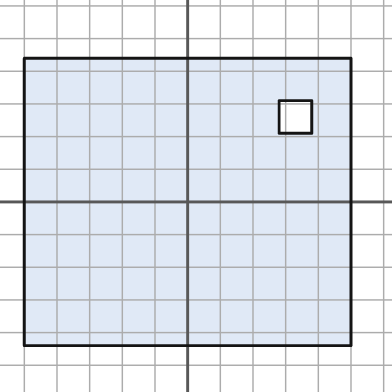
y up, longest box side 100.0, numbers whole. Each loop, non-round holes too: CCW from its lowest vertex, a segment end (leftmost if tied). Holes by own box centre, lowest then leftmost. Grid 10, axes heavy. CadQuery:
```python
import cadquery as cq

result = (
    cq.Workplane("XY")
    .moveTo(-50.0, -44.0)
    .lineTo(50.0, -44.0)
    .lineTo(50.0, 44.0)
    .lineTo(-50.0, 44.0)
    .close()
    .moveTo(28.0, 21.0)
    .lineTo(38.0, 21.0)
    .lineTo(38.0, 31.0)
    .lineTo(28.0, 31.0)
    .close()
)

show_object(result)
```